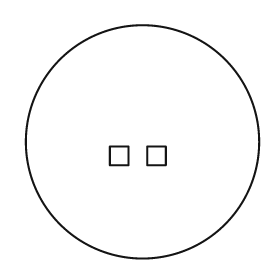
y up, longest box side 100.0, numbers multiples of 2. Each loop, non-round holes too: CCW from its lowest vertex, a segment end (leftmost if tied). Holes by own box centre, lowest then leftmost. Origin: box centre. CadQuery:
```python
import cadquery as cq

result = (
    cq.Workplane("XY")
    .moveTo(0.0, 0.0)
    .circle(50.0)
    .moveTo(-14.0, -10.0)
    .lineTo(-6.0, -10.0)
    .lineTo(-6.0, -2.0)
    .lineTo(-14.0, -2.0)
    .close()
    .moveTo(2.0, -10.0)
    .lineTo(10.0, -10.0)
    .lineTo(10.0, -2.0)
    .lineTo(2.0, -2.0)
    .close()
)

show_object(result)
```